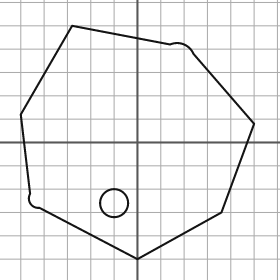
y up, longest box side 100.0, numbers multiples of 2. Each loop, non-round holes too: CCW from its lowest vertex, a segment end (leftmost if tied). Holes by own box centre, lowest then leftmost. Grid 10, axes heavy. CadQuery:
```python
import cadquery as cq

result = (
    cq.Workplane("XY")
    .moveTo(0.0, -50.0)
    .lineTo(36.0, -30.0)
    .lineTo(50.0, 8.0)
    .lineTo(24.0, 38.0)
    .threePointArc((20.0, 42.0), (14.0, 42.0))
    .lineTo(-28.0, 50.0)
    .lineTo(-50.0, 12.0)
    .lineTo(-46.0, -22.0)
    .threePointArc((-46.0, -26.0), (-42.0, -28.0))
    .close()
    .moveTo(-10.0, -26.0)
    .circle(6.0)
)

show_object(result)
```